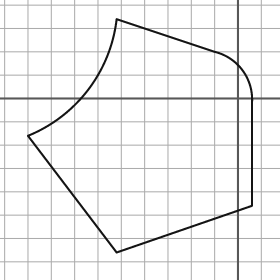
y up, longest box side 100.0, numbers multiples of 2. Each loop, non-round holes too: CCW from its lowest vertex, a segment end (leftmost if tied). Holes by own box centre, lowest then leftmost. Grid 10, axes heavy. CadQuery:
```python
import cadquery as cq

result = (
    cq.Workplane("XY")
    .moveTo(-52.0, -66.0)
    .lineTo(6.0, -46.0)
    .lineTo(6.0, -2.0)
    .threePointArc((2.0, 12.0), (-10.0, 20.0))
    .lineTo(-52.0, 34.0)
    .threePointArc((-64.0, 4.0), (-90.0, -16.0))
    .close()
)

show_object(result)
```